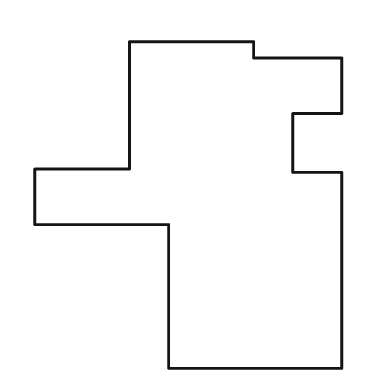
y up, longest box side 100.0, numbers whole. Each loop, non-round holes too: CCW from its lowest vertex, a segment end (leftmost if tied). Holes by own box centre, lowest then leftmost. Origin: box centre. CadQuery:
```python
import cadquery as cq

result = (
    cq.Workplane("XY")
    .moveTo(-6.0, -50.0)
    .lineTo(47.0, -50.0)
    .lineTo(47.0, 10.0)
    .lineTo(32.0, 10.0)
    .lineTo(32.0, 28.0)
    .lineTo(47.0, 28.0)
    .lineTo(47.0, 45.0)
    .lineTo(20.0, 45.0)
    .lineTo(20.0, 50.0)
    .lineTo(-18.0, 50.0)
    .lineTo(-18.0, 11.0)
    .lineTo(-47.0, 11.0)
    .lineTo(-47.0, -6.0)
    .lineTo(-6.0, -6.0)
    .close()
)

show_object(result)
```